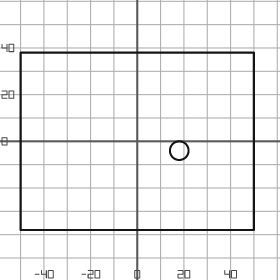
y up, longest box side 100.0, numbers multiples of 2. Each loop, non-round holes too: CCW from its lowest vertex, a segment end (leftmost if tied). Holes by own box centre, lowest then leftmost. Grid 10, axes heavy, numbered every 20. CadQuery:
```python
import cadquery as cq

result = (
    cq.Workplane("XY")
    .moveTo(-50.0, -38.0)
    .lineTo(50.0, -38.0)
    .lineTo(50.0, 38.0)
    .lineTo(-50.0, 38.0)
    .close()
    .moveTo(18.0, -4.0)
    .circle(4.0)
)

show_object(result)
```